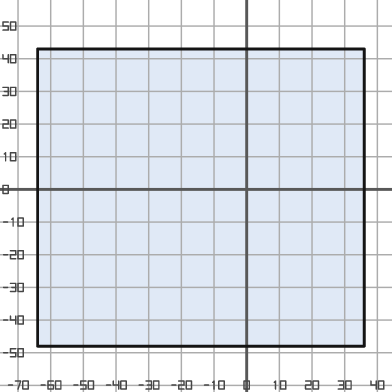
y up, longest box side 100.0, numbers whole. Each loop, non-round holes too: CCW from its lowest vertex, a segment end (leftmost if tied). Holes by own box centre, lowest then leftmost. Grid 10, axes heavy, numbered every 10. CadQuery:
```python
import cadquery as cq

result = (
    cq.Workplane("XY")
    .moveTo(-64.0, -48.0)
    .lineTo(36.0, -48.0)
    .lineTo(36.0, 43.0)
    .lineTo(-64.0, 43.0)
    .close()
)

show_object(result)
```